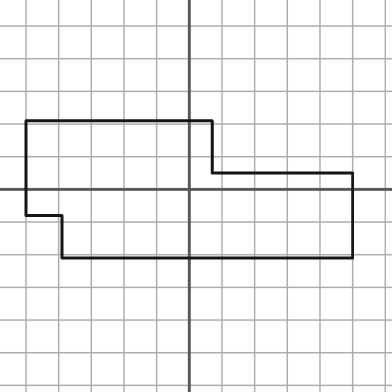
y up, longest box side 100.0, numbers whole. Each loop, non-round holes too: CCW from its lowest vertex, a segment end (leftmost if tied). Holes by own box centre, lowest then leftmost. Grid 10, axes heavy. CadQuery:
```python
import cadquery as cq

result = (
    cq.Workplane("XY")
    .moveTo(-39.0, -21.0)
    .lineTo(50.0, -21.0)
    .lineTo(50.0, 5.0)
    .lineTo(7.0, 5.0)
    .lineTo(7.0, 21.0)
    .lineTo(-50.0, 21.0)
    .lineTo(-50.0, -8.0)
    .lineTo(-39.0, -8.0)
    .close()
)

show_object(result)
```